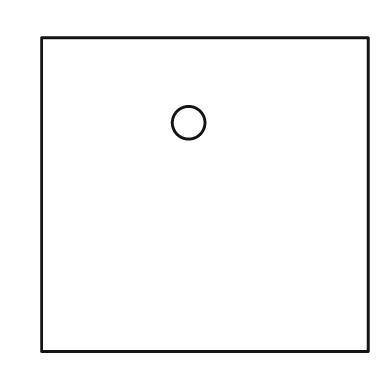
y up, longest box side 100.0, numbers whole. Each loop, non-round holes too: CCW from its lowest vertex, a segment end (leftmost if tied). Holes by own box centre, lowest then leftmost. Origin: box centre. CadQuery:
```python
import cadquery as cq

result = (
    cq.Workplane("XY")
    .moveTo(-50.0, -48.0)
    .lineTo(50.0, -48.0)
    .lineTo(50.0, 48.0)
    .lineTo(-50.0, 48.0)
    .close()
    .moveTo(-5.0, 22.0)
    .circle(5.0)
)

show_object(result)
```